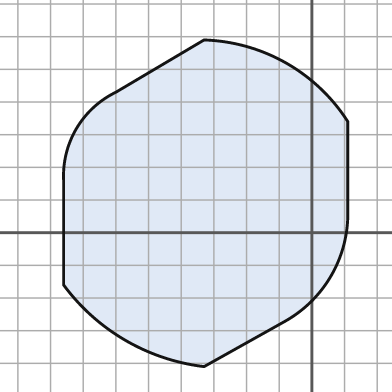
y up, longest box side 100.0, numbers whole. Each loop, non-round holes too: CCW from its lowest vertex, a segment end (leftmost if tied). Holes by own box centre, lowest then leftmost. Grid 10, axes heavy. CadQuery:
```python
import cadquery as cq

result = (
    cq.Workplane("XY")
    .moveTo(-33.0, -41.0)
    .lineTo(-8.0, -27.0)
    .threePointArc((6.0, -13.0), (11.0, 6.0))
    .lineTo(11.0, 34.0)
    .threePointArc((-8.0, 52.0), (-33.0, 59.0))
    .lineTo(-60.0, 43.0)
    .threePointArc((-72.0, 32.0), (-76.0, 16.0))
    .lineTo(-76.0, -16.0)
    .threePointArc((-57.0, -33.0), (-33.0, -41.0))
    .close()
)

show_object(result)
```